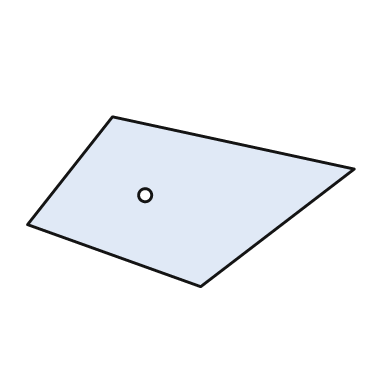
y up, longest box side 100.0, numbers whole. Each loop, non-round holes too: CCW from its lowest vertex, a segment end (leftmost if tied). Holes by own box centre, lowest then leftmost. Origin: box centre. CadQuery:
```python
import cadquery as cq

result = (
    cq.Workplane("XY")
    .moveTo(3.0, -26.0)
    .lineTo(50.0, 10.0)
    .lineTo(-24.0, 26.0)
    .lineTo(-50.0, -7.0)
    .close()
    .moveTo(-14.0, 2.0)
    .circle(2.0)
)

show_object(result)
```